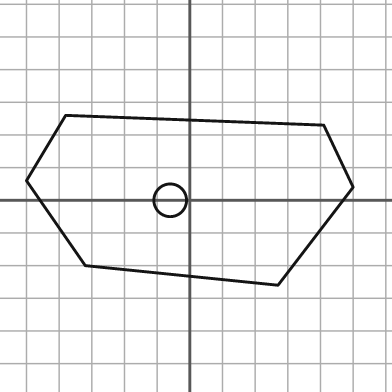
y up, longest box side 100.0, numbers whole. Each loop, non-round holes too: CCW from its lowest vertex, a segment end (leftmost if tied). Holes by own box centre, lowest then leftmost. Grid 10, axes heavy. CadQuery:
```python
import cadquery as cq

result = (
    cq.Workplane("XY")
    .moveTo(27.0, -26.0)
    .lineTo(50.0, 4.0)
    .lineTo(41.0, 23.0)
    .lineTo(-38.0, 26.0)
    .lineTo(-50.0, 6.0)
    .lineTo(-32.0, -20.0)
    .close()
    .moveTo(-6.0, 0.0)
    .circle(5.0)
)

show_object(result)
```